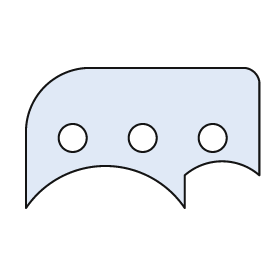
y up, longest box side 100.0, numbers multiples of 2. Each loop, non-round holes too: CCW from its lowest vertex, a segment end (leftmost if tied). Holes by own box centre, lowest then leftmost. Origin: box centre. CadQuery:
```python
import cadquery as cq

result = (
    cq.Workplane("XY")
    .moveTo(-50.0, -30.0)
    .threePointArc((-16.0, -12.0), (18.0, -30.0))
    .lineTo(18.0, -16.0)
    .threePointArc((34.0, -10.0), (50.0, -16.0))
    .lineTo(50.0, 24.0)
    .threePointArc((48.0, 28.0), (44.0, 30.0))
    .lineTo(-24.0, 30.0)
    .threePointArc((-42.0, 22.0), (-50.0, 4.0))
    .close()
    .moveTo(-30.0, 0.0)
    .circle(6.0)
    .moveTo(0.0, 0.0)
    .circle(6.0)
    .moveTo(30.0, 0.0)
    .circle(6.0)
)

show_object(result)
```